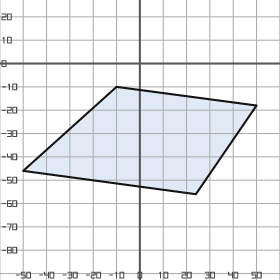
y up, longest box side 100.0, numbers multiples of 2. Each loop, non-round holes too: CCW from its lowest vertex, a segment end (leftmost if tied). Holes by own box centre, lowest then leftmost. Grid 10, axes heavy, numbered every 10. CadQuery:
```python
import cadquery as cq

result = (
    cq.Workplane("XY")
    .moveTo(24.0, -56.0)
    .lineTo(50.0, -18.0)
    .lineTo(-10.0, -10.0)
    .lineTo(-50.0, -46.0)
    .close()
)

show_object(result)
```